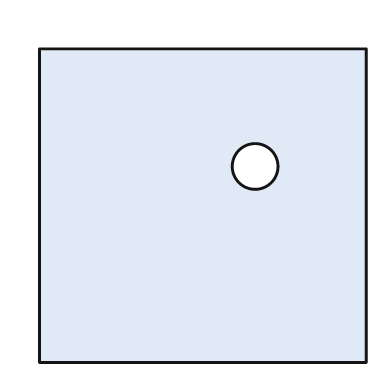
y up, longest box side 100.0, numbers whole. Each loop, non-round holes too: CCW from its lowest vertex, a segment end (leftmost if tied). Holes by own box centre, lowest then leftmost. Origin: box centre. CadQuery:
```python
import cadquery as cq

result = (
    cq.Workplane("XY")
    .moveTo(-50.0, -48.0)
    .lineTo(50.0, -48.0)
    .lineTo(50.0, 48.0)
    .lineTo(-50.0, 48.0)
    .close()
    .moveTo(16.0, 12.0)
    .circle(7.0)
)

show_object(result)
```